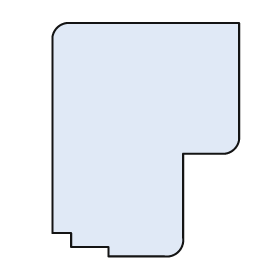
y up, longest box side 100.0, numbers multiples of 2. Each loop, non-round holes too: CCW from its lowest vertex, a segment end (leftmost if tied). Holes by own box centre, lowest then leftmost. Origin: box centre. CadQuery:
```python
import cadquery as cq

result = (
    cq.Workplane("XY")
    .moveTo(-16.0, -50.0)
    .lineTo(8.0, -50.0)
    .threePointArc((14.0, -48.0), (16.0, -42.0))
    .lineTo(16.0, -6.0)
    .lineTo(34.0, -6.0)
    .threePointArc((38.0, -4.0), (40.0, 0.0))
    .lineTo(40.0, 50.0)
    .lineTo(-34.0, 50.0)
    .threePointArc((-38.0, 48.0), (-40.0, 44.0))
    .lineTo(-40.0, -40.0)
    .lineTo(-32.0, -40.0)
    .lineTo(-32.0, -46.0)
    .lineTo(-16.0, -46.0)
    .close()
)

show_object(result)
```